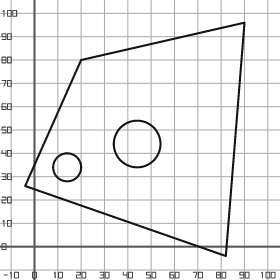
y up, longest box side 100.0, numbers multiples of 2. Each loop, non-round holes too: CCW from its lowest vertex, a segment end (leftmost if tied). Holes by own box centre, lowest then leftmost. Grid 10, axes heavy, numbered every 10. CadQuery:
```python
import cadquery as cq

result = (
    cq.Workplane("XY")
    .moveTo(82.0, -4.0)
    .lineTo(90.0, 96.0)
    .lineTo(20.0, 80.0)
    .lineTo(-4.0, 26.0)
    .close()
    .moveTo(14.0, 34.0)
    .circle(6.0)
    .moveTo(44.0, 44.0)
    .circle(10.0)
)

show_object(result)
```